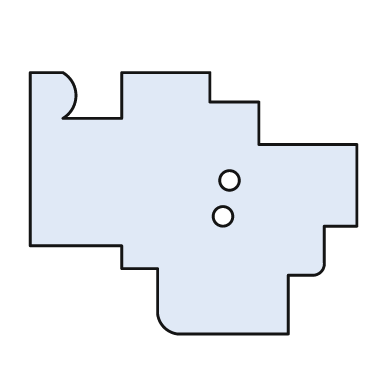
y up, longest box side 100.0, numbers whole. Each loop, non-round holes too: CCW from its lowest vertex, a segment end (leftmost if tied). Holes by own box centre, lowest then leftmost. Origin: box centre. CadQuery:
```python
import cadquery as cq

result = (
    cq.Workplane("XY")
    .moveTo(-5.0, -40.0)
    .lineTo(29.0, -40.0)
    .lineTo(29.0, -22.0)
    .lineTo(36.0, -22.0)
    .threePointArc((39.0, -21.0), (40.0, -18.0))
    .lineTo(40.0, -7.0)
    .lineTo(50.0, -7.0)
    .lineTo(50.0, 18.0)
    .lineTo(20.0, 18.0)
    .lineTo(20.0, 31.0)
    .lineTo(5.0, 31.0)
    .lineTo(5.0, 40.0)
    .lineTo(-22.0, 40.0)
    .lineTo(-22.0, 26.0)
    .lineTo(-40.0, 26.0)
    .threePointArc((-36.0, 33.0), (-40.0, 40.0))
    .lineTo(-50.0, 40.0)
    .lineTo(-50.0, -13.0)
    .lineTo(-22.0, -13.0)
    .lineTo(-22.0, -20.0)
    .lineTo(-11.0, -20.0)
    .lineTo(-11.0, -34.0)
    .threePointArc((-9.0, -38.0), (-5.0, -40.0))
    .close()
    .moveTo(9.0, -4.0)
    .circle(3.0)
    .moveTo(11.0, 7.0)
    .circle(3.0)
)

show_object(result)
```